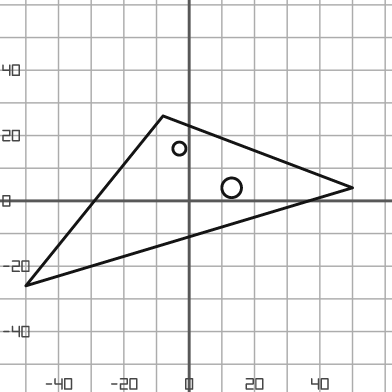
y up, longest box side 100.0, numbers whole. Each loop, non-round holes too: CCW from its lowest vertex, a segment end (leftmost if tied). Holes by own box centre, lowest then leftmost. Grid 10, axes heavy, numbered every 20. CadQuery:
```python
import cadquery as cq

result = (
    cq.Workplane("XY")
    .moveTo(-50.0, -26.0)
    .lineTo(50.0, 4.0)
    .lineTo(-8.0, 26.0)
    .close()
    .moveTo(13.0, 4.0)
    .circle(3.0)
    .moveTo(-3.0, 16.0)
    .circle(2.0)
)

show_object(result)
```